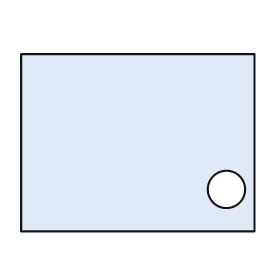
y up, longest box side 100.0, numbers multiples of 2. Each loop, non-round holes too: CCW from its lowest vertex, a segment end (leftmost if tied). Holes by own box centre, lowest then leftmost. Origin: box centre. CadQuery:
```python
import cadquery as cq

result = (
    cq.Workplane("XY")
    .moveTo(-50.0, -38.0)
    .lineTo(50.0, -38.0)
    .lineTo(50.0, 38.0)
    .lineTo(-50.0, 38.0)
    .close()
    .moveTo(38.0, -20.0)
    .circle(8.0)
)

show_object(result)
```